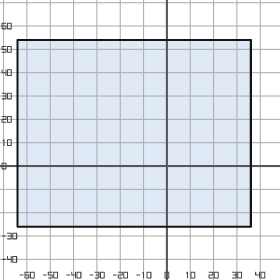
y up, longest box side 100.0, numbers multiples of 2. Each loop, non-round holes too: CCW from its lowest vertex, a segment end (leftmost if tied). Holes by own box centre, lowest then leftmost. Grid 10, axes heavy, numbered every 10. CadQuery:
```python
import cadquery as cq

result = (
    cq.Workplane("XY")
    .moveTo(-64.0, -26.0)
    .lineTo(36.0, -26.0)
    .lineTo(36.0, 54.0)
    .lineTo(-64.0, 54.0)
    .close()
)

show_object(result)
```